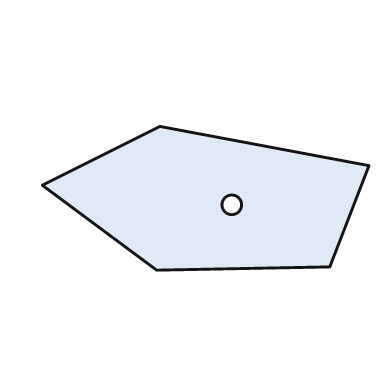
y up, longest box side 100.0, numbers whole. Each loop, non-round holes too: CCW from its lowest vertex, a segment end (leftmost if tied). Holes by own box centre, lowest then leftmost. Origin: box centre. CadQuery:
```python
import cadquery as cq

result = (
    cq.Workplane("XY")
    .moveTo(-15.0, -22.0)
    .lineTo(38.0, -21.0)
    .lineTo(50.0, 10.0)
    .lineTo(-14.0, 22.0)
    .lineTo(-50.0, 4.0)
    .close()
    .moveTo(8.0, -2.0)
    .circle(3.0)
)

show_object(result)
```